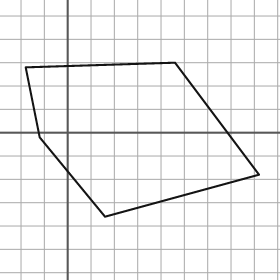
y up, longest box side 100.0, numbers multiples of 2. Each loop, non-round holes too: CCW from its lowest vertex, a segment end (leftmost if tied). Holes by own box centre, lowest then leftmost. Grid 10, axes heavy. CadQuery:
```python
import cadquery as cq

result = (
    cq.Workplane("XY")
    .moveTo(16.0, -36.0)
    .lineTo(82.0, -18.0)
    .lineTo(46.0, 30.0)
    .lineTo(-18.0, 28.0)
    .lineTo(-12.0, -2.0)
    .close()
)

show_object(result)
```